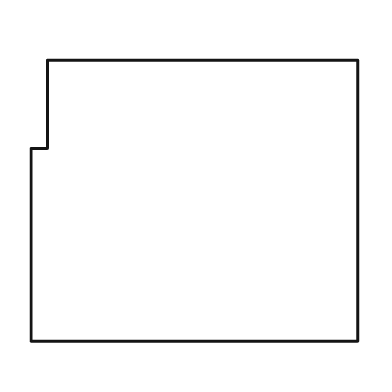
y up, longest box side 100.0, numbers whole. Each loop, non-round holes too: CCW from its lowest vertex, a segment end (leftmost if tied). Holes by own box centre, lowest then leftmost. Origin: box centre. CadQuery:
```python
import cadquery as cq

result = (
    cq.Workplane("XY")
    .moveTo(-50.0, -43.0)
    .lineTo(50.0, -43.0)
    .lineTo(50.0, 43.0)
    .lineTo(-45.0, 43.0)
    .lineTo(-45.0, 16.0)
    .lineTo(-50.0, 16.0)
    .close()
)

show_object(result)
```